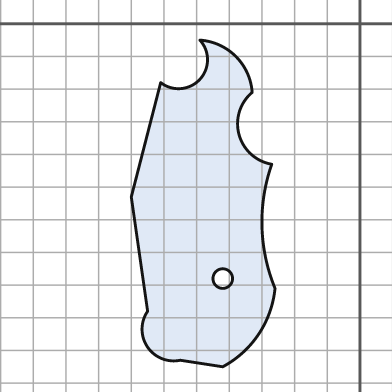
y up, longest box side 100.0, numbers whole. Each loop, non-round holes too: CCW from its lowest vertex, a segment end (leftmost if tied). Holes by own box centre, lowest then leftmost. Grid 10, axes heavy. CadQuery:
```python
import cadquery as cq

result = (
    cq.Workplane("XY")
    .moveTo(-42.0, -105.0)
    .threePointArc((-31.0, -95.0), (-26.0, -81.0))
    .threePointArc((-30.0, -62.0), (-27.0, -43.0))
    .threePointArc((-37.0, -34.0), (-33.0, -21.0))
    .threePointArc((-38.0, -10.0), (-49.0, -5.0))
    .threePointArc((-49.0, -17.0), (-61.0, -18.0))
    .lineTo(-70.0, -53.0)
    .lineTo(-65.0, -88.0)
    .threePointArc((-65.0, -99.0), (-55.0, -103.0))
    .close()
    .moveTo(-42.0, -78.0)
    .circle(3.0)
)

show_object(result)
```